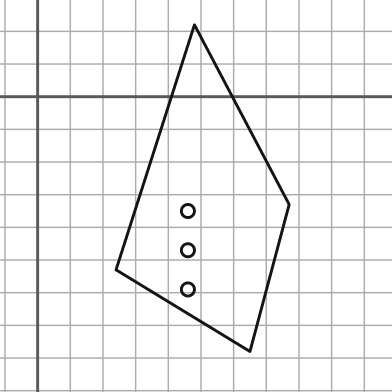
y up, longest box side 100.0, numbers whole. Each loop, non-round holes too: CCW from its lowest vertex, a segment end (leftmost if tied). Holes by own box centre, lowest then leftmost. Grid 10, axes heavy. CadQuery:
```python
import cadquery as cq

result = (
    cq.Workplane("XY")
    .moveTo(65.0, -78.0)
    .lineTo(77.0, -33.0)
    .lineTo(48.0, 22.0)
    .lineTo(24.0, -53.0)
    .close()
    .moveTo(46.0, -59.0)
    .circle(2.0)
    .moveTo(46.0, -47.0)
    .circle(2.0)
    .moveTo(46.0, -35.0)
    .circle(2.0)
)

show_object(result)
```